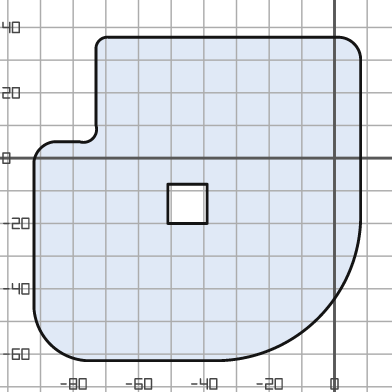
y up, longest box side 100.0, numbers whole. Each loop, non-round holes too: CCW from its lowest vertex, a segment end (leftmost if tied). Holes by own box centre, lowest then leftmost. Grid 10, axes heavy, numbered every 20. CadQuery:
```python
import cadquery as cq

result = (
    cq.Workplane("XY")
    .moveTo(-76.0, -62.0)
    .lineTo(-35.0, -62.0)
    .threePointArc((-5.0, -49.0), (8.0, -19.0))
    .lineTo(8.0, 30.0)
    .threePointArc((6.0, 35.0), (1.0, 37.0))
    .lineTo(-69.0, 37.0)
    .threePointArc((-72.0, 36.0), (-73.0, 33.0))
    .lineTo(-73.0, 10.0)
    .threePointArc((-74.0, 6.0), (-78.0, 5.0))
    .lineTo(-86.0, 5.0)
    .threePointArc((-90.0, 3.0), (-92.0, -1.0))
    .lineTo(-92.0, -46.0)
    .threePointArc((-87.0, -57.0), (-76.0, -62.0))
    .close()
    .moveTo(-51.0, -20.0)
    .lineTo(-39.0, -20.0)
    .lineTo(-39.0, -8.0)
    .lineTo(-51.0, -8.0)
    .close()
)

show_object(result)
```